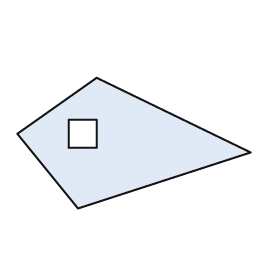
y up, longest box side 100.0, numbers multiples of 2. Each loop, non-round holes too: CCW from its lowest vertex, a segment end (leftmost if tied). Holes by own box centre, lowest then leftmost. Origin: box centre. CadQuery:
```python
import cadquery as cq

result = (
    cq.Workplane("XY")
    .moveTo(-24.0, -28.0)
    .lineTo(50.0, -4.0)
    .lineTo(-16.0, 28.0)
    .lineTo(-50.0, 4.0)
    .close()
    .moveTo(-28.0, -2.0)
    .lineTo(-16.0, -2.0)
    .lineTo(-16.0, 10.0)
    .lineTo(-28.0, 10.0)
    .close()
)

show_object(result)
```